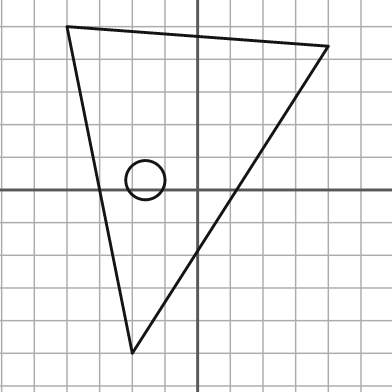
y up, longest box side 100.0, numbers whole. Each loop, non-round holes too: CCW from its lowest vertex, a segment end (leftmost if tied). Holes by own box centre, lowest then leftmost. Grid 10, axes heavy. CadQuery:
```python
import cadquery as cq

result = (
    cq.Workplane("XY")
    .moveTo(-20.0, -50.0)
    .lineTo(40.0, 44.0)
    .lineTo(-40.0, 50.0)
    .close()
    .moveTo(-16.0, 3.0)
    .circle(6.0)
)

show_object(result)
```